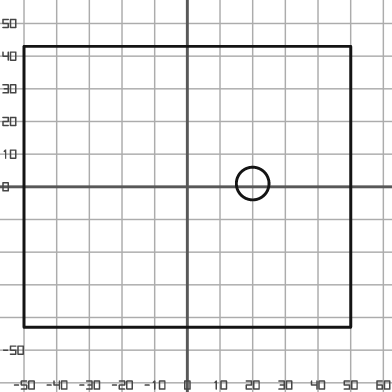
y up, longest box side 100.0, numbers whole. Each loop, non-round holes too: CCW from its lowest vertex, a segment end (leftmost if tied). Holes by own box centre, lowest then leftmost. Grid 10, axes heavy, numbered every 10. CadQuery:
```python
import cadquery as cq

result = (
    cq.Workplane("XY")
    .moveTo(-50.0, -43.0)
    .lineTo(50.0, -43.0)
    .lineTo(50.0, 43.0)
    .lineTo(-50.0, 43.0)
    .close()
    .moveTo(20.0, 1.0)
    .circle(5.0)
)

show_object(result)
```